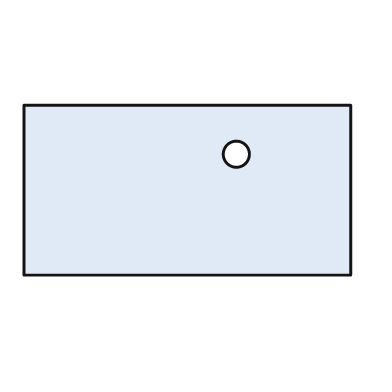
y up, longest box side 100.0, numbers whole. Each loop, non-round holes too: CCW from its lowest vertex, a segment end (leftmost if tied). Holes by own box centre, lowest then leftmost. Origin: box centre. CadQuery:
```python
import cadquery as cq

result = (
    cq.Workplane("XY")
    .moveTo(-50.0, -26.0)
    .lineTo(50.0, -26.0)
    .lineTo(50.0, 26.0)
    .lineTo(-50.0, 26.0)
    .close()
    .moveTo(15.0, 11.0)
    .circle(4.0)
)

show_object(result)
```